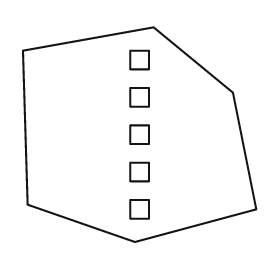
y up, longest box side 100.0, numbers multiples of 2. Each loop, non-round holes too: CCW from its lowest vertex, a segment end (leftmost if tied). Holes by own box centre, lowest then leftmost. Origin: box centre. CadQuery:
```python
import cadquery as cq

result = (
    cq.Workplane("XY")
    .moveTo(-2.0, -46.0)
    .lineTo(50.0, -32.0)
    .lineTo(40.0, 18.0)
    .lineTo(6.0, 46.0)
    .lineTo(-50.0, 36.0)
    .lineTo(-48.0, -30.0)
    .close()
    .moveTo(-4.0, -36.0)
    .lineTo(4.0, -36.0)
    .lineTo(4.0, -28.0)
    .lineTo(-4.0, -28.0)
    .close()
    .moveTo(-4.0, -20.0)
    .lineTo(4.0, -20.0)
    .lineTo(4.0, -12.0)
    .lineTo(-4.0, -12.0)
    .close()
    .moveTo(-4.0, -4.0)
    .lineTo(4.0, -4.0)
    .lineTo(4.0, 4.0)
    .lineTo(-4.0, 4.0)
    .close()
    .moveTo(-4.0, 12.0)
    .lineTo(4.0, 12.0)
    .lineTo(4.0, 20.0)
    .lineTo(-4.0, 20.0)
    .close()
    .moveTo(-4.0, 28.0)
    .lineTo(4.0, 28.0)
    .lineTo(4.0, 36.0)
    .lineTo(-4.0, 36.0)
    .close()
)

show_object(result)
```